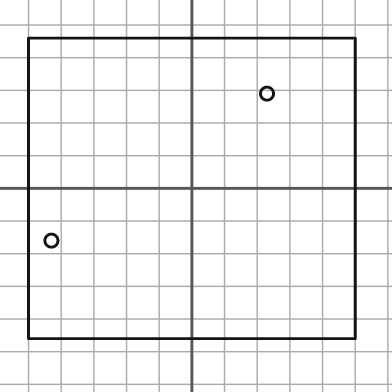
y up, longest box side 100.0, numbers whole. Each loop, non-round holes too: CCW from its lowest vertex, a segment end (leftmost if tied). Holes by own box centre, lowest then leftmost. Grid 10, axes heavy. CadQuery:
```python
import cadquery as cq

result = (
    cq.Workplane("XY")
    .moveTo(-50.0, -46.0)
    .lineTo(50.0, -46.0)
    .lineTo(50.0, 46.0)
    .lineTo(-50.0, 46.0)
    .close()
    .moveTo(-43.0, -16.0)
    .circle(2.0)
    .moveTo(23.0, 29.0)
    .circle(2.0)
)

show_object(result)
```